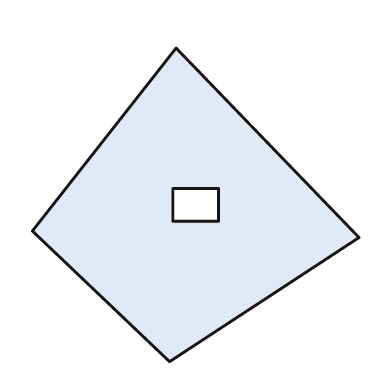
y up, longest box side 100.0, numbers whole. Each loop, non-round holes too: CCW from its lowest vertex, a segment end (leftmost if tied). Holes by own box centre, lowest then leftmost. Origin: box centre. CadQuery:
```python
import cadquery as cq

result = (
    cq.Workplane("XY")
    .moveTo(-8.0, -48.0)
    .lineTo(50.0, -10.0)
    .lineTo(-6.0, 48.0)
    .lineTo(-50.0, -8.0)
    .close()
    .moveTo(-7.0, -5.0)
    .lineTo(7.0, -5.0)
    .lineTo(7.0, 5.0)
    .lineTo(-7.0, 5.0)
    .close()
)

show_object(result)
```